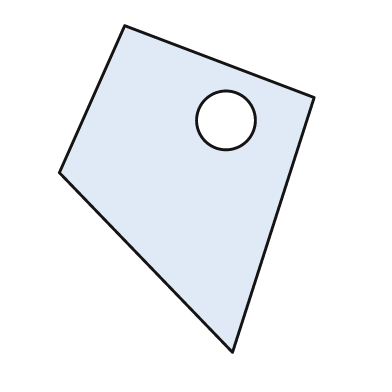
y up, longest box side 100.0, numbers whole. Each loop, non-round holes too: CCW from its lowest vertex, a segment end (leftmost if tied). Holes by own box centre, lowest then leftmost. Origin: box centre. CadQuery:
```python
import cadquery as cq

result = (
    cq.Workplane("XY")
    .moveTo(14.0, -50.0)
    .lineTo(39.0, 28.0)
    .lineTo(-19.0, 50.0)
    .lineTo(-39.0, 5.0)
    .close()
    .moveTo(12.0, 21.0)
    .circle(9.0)
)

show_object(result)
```